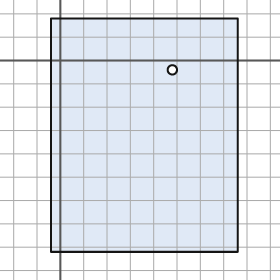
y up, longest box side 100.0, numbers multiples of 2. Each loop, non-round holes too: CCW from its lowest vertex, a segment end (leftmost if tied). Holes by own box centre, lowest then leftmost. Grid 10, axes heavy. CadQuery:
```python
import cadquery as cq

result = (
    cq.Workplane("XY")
    .moveTo(-4.0, -82.0)
    .lineTo(76.0, -82.0)
    .lineTo(76.0, 18.0)
    .lineTo(-4.0, 18.0)
    .close()
    .moveTo(48.0, -4.0)
    .circle(2.0)
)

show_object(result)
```